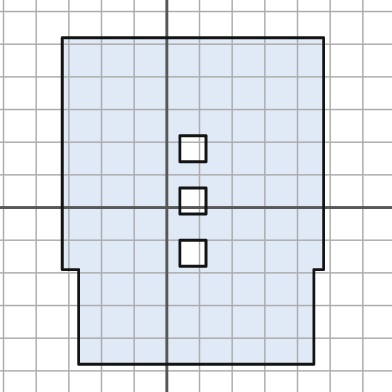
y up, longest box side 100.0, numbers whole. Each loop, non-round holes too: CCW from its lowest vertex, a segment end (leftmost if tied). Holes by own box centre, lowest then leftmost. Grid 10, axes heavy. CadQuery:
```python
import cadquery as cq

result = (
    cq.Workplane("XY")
    .moveTo(-27.0, -48.0)
    .lineTo(45.0, -48.0)
    .lineTo(45.0, -19.0)
    .lineTo(48.0, -19.0)
    .lineTo(48.0, 52.0)
    .lineTo(-32.0, 52.0)
    .lineTo(-32.0, -19.0)
    .lineTo(-27.0, -19.0)
    .close()
    .moveTo(4.0, -18.0)
    .lineTo(12.0, -18.0)
    .lineTo(12.0, -10.0)
    .lineTo(4.0, -10.0)
    .close()
    .moveTo(4.0, -2.0)
    .lineTo(12.0, -2.0)
    .lineTo(12.0, 6.0)
    .lineTo(4.0, 6.0)
    .close()
    .moveTo(4.0, 14.0)
    .lineTo(12.0, 14.0)
    .lineTo(12.0, 22.0)
    .lineTo(4.0, 22.0)
    .close()
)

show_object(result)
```